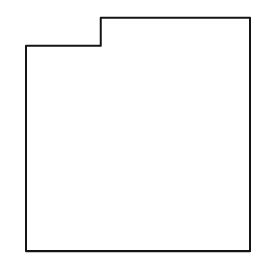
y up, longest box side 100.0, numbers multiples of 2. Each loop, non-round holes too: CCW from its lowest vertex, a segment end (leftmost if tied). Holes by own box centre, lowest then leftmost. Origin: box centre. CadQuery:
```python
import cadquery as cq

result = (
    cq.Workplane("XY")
    .moveTo(-48.0, -50.0)
    .lineTo(48.0, -50.0)
    .lineTo(48.0, 50.0)
    .lineTo(-16.0, 50.0)
    .lineTo(-16.0, 38.0)
    .lineTo(-48.0, 38.0)
    .close()
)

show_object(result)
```